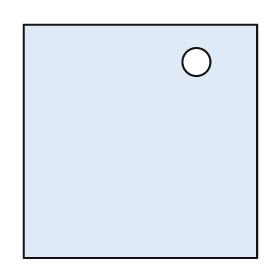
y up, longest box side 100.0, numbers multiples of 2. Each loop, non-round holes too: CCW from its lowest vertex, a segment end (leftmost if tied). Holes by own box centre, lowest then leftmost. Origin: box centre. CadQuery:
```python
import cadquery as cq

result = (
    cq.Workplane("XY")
    .moveTo(-50.0, -50.0)
    .lineTo(50.0, -50.0)
    .lineTo(50.0, 50.0)
    .lineTo(-50.0, 50.0)
    .close()
    .moveTo(24.0, 34.0)
    .circle(6.0)
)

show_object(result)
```